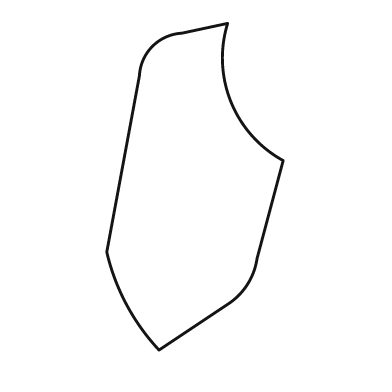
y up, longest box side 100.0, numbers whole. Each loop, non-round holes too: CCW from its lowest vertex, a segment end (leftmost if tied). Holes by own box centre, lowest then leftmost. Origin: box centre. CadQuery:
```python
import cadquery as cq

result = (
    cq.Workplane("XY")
    .moveTo(-11.0, -50.0)
    .lineTo(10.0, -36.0)
    .threePointArc((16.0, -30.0), (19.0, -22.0))
    .lineTo(27.0, 8.0)
    .threePointArc((11.0, 26.0), (10.0, 50.0))
    .lineTo(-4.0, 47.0)
    .threePointArc((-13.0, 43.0), (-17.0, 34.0))
    .lineTo(-27.0, -20.0)
    .threePointArc((-21.0, -36.0), (-11.0, -50.0))
    .close()
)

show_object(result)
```